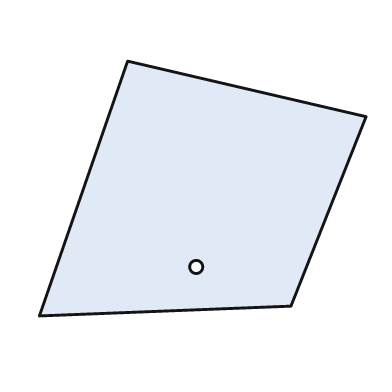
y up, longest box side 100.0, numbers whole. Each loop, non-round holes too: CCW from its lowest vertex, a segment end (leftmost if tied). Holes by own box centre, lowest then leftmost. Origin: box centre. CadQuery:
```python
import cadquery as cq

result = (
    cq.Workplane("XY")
    .moveTo(-50.0, -39.0)
    .lineTo(27.0, -36.0)
    .lineTo(50.0, 22.0)
    .lineTo(-23.0, 39.0)
    .close()
    .moveTo(-2.0, -24.0)
    .circle(2.0)
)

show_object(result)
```